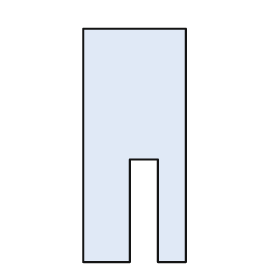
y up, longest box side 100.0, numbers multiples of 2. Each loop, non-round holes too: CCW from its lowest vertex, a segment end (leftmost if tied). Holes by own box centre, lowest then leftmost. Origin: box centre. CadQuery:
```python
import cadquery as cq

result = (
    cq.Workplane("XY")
    .moveTo(-22.0, -50.0)
    .lineTo(-2.0, -50.0)
    .lineTo(-2.0, -6.0)
    .lineTo(10.0, -6.0)
    .lineTo(10.0, -50.0)
    .lineTo(22.0, -50.0)
    .lineTo(22.0, 50.0)
    .lineTo(-22.0, 50.0)
    .close()
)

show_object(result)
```